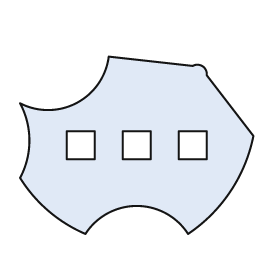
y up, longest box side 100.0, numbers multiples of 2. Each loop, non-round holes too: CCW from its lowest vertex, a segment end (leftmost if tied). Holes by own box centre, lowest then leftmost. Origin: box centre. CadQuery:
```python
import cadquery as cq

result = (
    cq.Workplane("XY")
    .moveTo(-22.0, -38.0)
    .threePointArc((0.0, -26.0), (22.0, -38.0))
    .threePointArc((40.0, -20.0), (50.0, 4.0))
    .lineTo(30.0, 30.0)
    .threePointArc((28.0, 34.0), (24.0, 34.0))
    .lineTo(-12.0, 38.0)
    .threePointArc((-26.0, 18.0), (-50.0, 18.0))
    .threePointArc((-46.0, 2.0), (-50.0, -14.0))
    .threePointArc((-38.0, -28.0), (-22.0, -38.0))
    .close()
    .moveTo(-30.0, -6.0)
    .lineTo(-18.0, -6.0)
    .lineTo(-18.0, 6.0)
    .lineTo(-30.0, 6.0)
    .close()
    .moveTo(-6.0, -6.0)
    .lineTo(6.0, -6.0)
    .lineTo(6.0, 6.0)
    .lineTo(-6.0, 6.0)
    .close()
    .moveTo(18.0, -6.0)
    .lineTo(30.0, -6.0)
    .lineTo(30.0, 6.0)
    .lineTo(18.0, 6.0)
    .close()
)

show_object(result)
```